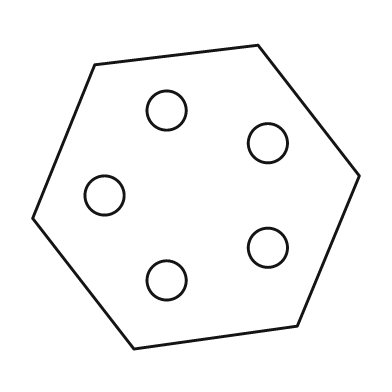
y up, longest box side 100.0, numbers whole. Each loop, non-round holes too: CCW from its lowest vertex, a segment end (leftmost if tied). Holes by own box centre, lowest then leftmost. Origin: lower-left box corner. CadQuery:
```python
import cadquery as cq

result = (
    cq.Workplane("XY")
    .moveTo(31.0, 0.0)
    .lineTo(81.0, 7.0)
    .lineTo(100.0, 53.0)
    .lineTo(69.0, 93.0)
    .lineTo(19.0, 87.0)
    .lineTo(0.0, 40.0)
    .close()
    .moveTo(41.0, 21.0)
    .circle(6.0)
    .moveTo(72.0, 31.0)
    .circle(6.0)
    .moveTo(22.0, 47.0)
    .circle(6.0)
    .moveTo(72.0, 63.0)
    .circle(6.0)
    .moveTo(41.0, 73.0)
    .circle(6.0)
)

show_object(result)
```